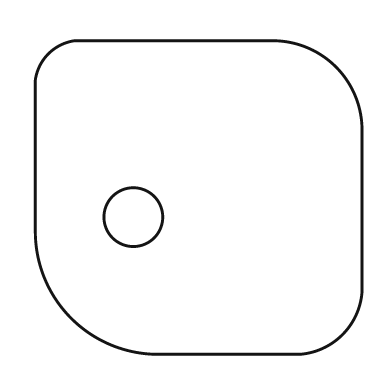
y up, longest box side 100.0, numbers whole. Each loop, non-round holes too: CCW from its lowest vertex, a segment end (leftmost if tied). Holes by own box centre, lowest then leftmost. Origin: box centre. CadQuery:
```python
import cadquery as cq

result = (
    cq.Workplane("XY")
    .moveTo(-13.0, -48.0)
    .lineTo(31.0, -48.0)
    .threePointArc((44.0, -42.0), (50.0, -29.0))
    .lineTo(50.0, 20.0)
    .threePointArc((42.0, 40.0), (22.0, 48.0))
    .lineTo(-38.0, 48.0)
    .threePointArc((-46.0, 44.0), (-50.0, 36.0))
    .lineTo(-50.0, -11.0)
    .threePointArc((-39.0, -37.0), (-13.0, -48.0))
    .close()
    .moveTo(-20.0, -6.0)
    .circle(9.0)
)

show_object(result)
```